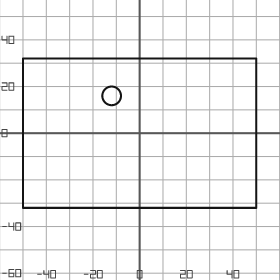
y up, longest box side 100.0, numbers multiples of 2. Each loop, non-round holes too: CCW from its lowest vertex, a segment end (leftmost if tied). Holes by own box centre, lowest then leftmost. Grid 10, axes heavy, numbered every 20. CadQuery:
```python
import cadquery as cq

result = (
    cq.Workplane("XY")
    .moveTo(-50.0, -32.0)
    .lineTo(50.0, -32.0)
    .lineTo(50.0, 32.0)
    .lineTo(-50.0, 32.0)
    .close()
    .moveTo(-12.0, 16.0)
    .circle(4.0)
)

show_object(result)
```